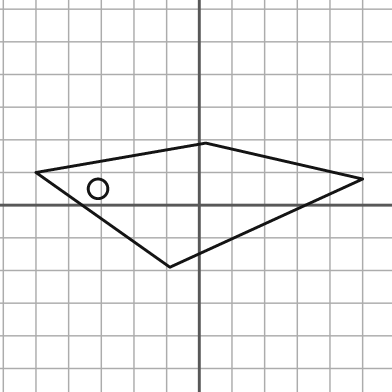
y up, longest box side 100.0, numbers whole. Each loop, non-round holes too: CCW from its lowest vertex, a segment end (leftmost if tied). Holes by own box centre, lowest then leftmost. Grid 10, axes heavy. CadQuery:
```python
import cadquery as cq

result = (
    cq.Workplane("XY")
    .moveTo(-9.0, -19.0)
    .lineTo(50.0, 8.0)
    .lineTo(2.0, 19.0)
    .lineTo(-50.0, 10.0)
    .close()
    .moveTo(-31.0, 5.0)
    .circle(3.0)
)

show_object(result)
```